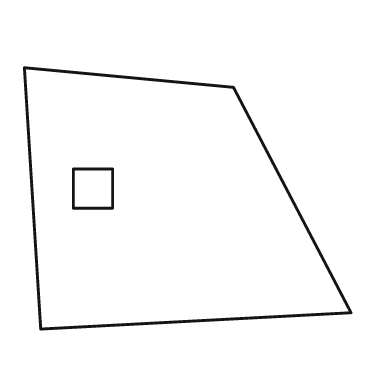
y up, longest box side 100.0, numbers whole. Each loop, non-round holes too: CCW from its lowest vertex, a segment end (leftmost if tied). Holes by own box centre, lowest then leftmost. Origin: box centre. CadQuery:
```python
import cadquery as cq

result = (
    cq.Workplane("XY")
    .moveTo(-45.0, -40.0)
    .lineTo(50.0, -35.0)
    .lineTo(14.0, 34.0)
    .lineTo(-50.0, 40.0)
    .close()
    .moveTo(-35.0, -3.0)
    .lineTo(-23.0, -3.0)
    .lineTo(-23.0, 9.0)
    .lineTo(-35.0, 9.0)
    .close()
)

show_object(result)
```